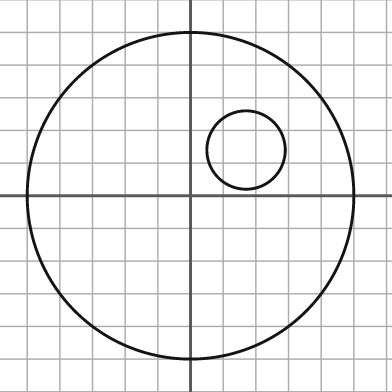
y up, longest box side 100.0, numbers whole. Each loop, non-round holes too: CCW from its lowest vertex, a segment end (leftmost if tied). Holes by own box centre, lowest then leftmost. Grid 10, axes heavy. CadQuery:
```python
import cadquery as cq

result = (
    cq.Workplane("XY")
    .moveTo(0.0, 0.0)
    .circle(50.0)
    .moveTo(17.0, 14.0)
    .circle(12.0)
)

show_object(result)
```